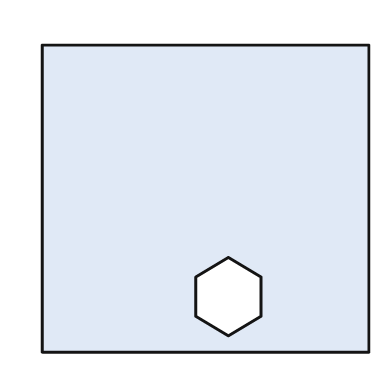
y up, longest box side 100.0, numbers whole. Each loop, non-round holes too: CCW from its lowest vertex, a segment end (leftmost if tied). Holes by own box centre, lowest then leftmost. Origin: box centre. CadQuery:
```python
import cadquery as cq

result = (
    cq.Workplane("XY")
    .moveTo(-50.0, -47.0)
    .lineTo(50.0, -47.0)
    .lineTo(50.0, 47.0)
    .lineTo(-50.0, 47.0)
    .close()
    .moveTo(7.0, -42.0)
    .lineTo(17.0, -36.0)
    .lineTo(17.0, -24.0)
    .lineTo(7.0, -18.0)
    .lineTo(-3.0, -24.0)
    .lineTo(-3.0, -36.0)
    .close()
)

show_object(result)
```